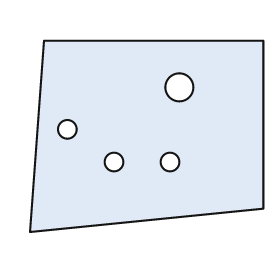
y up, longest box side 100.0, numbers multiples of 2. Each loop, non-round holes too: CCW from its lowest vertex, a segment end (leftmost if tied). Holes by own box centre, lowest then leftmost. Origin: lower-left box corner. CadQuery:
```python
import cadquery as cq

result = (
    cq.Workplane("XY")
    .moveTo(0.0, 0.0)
    .lineTo(100.0, 10.0)
    .lineTo(100.0, 82.0)
    .lineTo(6.0, 82.0)
    .close()
    .moveTo(36.0, 30.0)
    .circle(4.0)
    .moveTo(60.0, 30.0)
    .circle(4.0)
    .moveTo(16.0, 44.0)
    .circle(4.0)
    .moveTo(64.0, 62.0)
    .circle(6.0)
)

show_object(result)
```